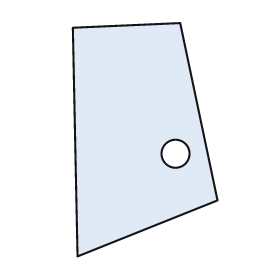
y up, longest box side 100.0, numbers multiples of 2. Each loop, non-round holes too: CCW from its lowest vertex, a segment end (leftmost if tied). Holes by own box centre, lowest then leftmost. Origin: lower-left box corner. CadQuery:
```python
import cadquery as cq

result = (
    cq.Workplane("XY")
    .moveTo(2.0, 0.0)
    .lineTo(62.0, 24.0)
    .lineTo(46.0, 100.0)
    .lineTo(0.0, 98.0)
    .close()
    .moveTo(44.0, 44.0)
    .circle(6.0)
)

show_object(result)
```